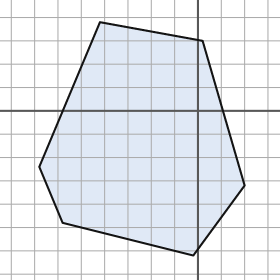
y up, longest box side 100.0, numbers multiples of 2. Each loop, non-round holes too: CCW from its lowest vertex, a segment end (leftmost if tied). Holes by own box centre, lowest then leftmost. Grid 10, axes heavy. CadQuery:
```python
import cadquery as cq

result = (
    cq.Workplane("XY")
    .moveTo(-2.0, -62.0)
    .lineTo(20.0, -32.0)
    .lineTo(2.0, 30.0)
    .lineTo(-42.0, 38.0)
    .lineTo(-68.0, -24.0)
    .lineTo(-58.0, -48.0)
    .close()
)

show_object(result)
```